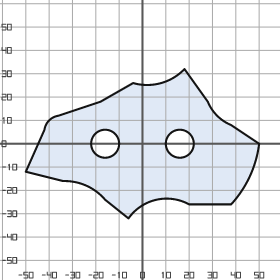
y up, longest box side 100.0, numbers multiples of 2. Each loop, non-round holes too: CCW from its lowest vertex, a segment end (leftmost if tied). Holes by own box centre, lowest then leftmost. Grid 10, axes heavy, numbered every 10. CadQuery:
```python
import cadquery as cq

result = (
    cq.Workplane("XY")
    .moveTo(-6.0, -32.0)
    .threePointArc((6.0, -24.0), (20.0, -26.0))
    .lineTo(38.0, -26.0)
    .threePointArc((46.0, -14.0), (50.0, 0.0))
    .lineTo(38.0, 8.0)
    .threePointArc((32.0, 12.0), (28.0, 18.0))
    .lineTo(18.0, 32.0)
    .threePointArc((8.0, 26.0), (-4.0, 26.0))
    .lineTo(-18.0, 18.0)
    .lineTo(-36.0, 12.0)
    .threePointArc((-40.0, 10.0), (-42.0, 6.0))
    .lineTo(-50.0, -12.0)
    .lineTo(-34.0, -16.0)
    .threePointArc((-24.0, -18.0), (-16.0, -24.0))
    .close()
    .moveTo(-16.0, 0.0)
    .circle(6.0)
    .moveTo(16.0, 0.0)
    .circle(6.0)
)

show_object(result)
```